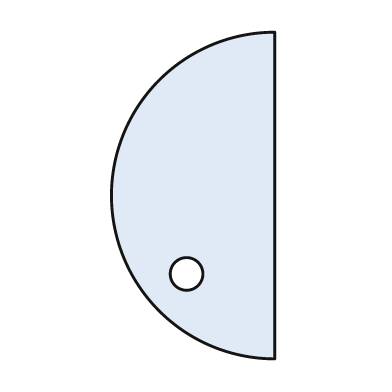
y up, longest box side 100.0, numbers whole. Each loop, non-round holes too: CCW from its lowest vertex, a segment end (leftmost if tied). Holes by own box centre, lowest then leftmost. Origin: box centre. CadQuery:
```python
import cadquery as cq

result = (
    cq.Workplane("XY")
    .moveTo(25.0, -50.0)
    .lineTo(25.0, 50.0)
    .threePointArc((-25.0, 0.0), (25.0, -50.0))
    .close()
    .moveTo(-2.0, -24.0)
    .circle(5.0)
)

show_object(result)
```